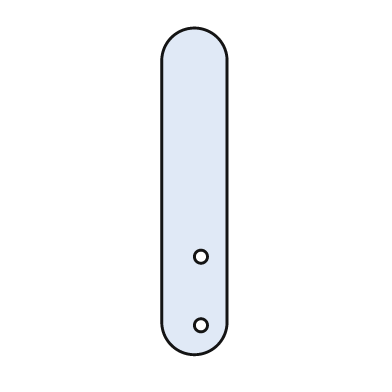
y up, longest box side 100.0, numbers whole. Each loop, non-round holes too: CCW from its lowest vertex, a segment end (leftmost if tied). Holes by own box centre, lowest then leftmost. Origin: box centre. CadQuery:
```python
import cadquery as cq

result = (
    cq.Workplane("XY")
    .moveTo(-10.0, -40.0)
    .threePointArc((0.0, -50.0), (10.0, -40.0))
    .lineTo(10.0, 40.0)
    .threePointArc((0.0, 50.0), (-10.0, 40.0))
    .close()
    .moveTo(2.0, -41.0)
    .circle(2.0)
    .moveTo(2.0, -20.0)
    .circle(2.0)
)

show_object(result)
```